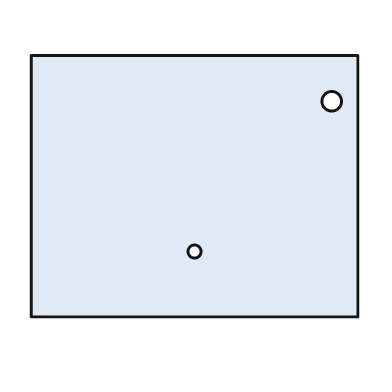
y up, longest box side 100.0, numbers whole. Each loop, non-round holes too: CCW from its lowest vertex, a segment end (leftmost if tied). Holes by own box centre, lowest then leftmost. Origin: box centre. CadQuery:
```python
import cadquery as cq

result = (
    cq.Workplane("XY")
    .moveTo(-50.0, -40.0)
    .lineTo(50.0, -40.0)
    .lineTo(50.0, 40.0)
    .lineTo(-50.0, 40.0)
    .close()
    .moveTo(0.0, -20.0)
    .circle(2.0)
    .moveTo(42.0, 26.0)
    .circle(3.0)
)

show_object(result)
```